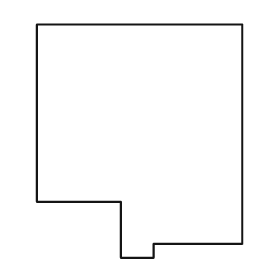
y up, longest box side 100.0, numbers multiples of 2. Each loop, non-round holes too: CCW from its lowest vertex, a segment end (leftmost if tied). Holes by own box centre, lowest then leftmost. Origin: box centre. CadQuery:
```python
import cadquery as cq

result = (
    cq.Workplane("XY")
    .moveTo(-8.0, -50.0)
    .lineTo(6.0, -50.0)
    .lineTo(6.0, -44.0)
    .lineTo(44.0, -44.0)
    .lineTo(44.0, 50.0)
    .lineTo(-44.0, 50.0)
    .lineTo(-44.0, -26.0)
    .lineTo(-8.0, -26.0)
    .close()
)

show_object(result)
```